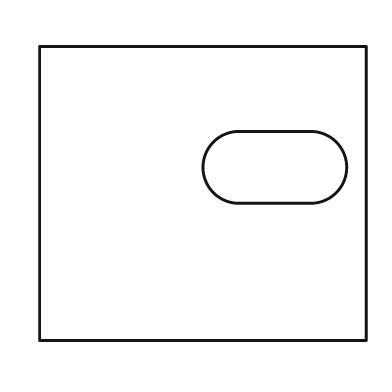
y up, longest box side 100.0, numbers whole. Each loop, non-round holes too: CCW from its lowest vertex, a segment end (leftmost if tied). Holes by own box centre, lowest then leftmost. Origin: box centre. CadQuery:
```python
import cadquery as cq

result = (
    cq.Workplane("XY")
    .moveTo(-50.0, -45.0)
    .lineTo(50.0, -45.0)
    .lineTo(50.0, 45.0)
    .lineTo(-50.0, 45.0)
    .close()
    .moveTo(11.0, -3.0)
    .lineTo(33.0, -3.0)
    .threePointArc((44.0, 8.0), (33.0, 19.0))
    .lineTo(11.0, 19.0)
    .threePointArc((0.0, 8.0), (11.0, -3.0))
    .close()
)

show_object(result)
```